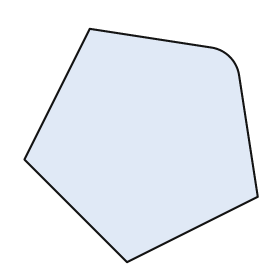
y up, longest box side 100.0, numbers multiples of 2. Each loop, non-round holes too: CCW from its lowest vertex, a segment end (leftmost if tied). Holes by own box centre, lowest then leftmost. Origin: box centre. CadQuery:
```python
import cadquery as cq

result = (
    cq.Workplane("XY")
    .moveTo(-6.0, -50.0)
    .lineTo(50.0, -22.0)
    .lineTo(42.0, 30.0)
    .threePointArc((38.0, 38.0), (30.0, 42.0))
    .lineTo(-22.0, 50.0)
    .lineTo(-50.0, -6.0)
    .close()
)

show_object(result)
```